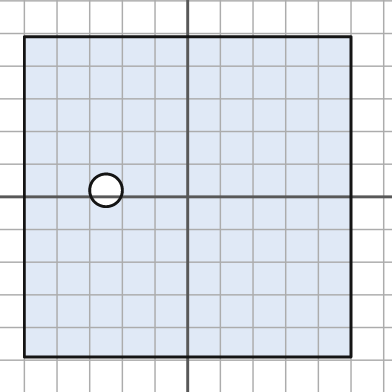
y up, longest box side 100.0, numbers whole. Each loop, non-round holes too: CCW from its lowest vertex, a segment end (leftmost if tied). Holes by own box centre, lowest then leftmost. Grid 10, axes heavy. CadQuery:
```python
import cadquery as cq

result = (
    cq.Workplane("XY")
    .moveTo(-50.0, -49.0)
    .lineTo(50.0, -49.0)
    .lineTo(50.0, 49.0)
    .lineTo(-50.0, 49.0)
    .close()
    .moveTo(-25.0, 2.0)
    .circle(5.0)
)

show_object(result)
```